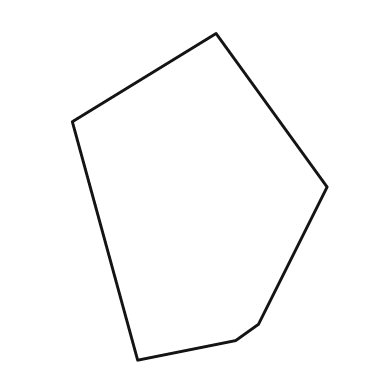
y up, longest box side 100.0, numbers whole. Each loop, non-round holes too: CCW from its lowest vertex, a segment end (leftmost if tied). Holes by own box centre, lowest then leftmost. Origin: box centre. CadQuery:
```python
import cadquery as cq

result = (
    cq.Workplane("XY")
    .moveTo(-19.0, -50.0)
    .lineTo(11.0, -44.0)
    .lineTo(18.0, -39.0)
    .lineTo(39.0, 3.0)
    .lineTo(5.0, 50.0)
    .lineTo(-39.0, 23.0)
    .close()
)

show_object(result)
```